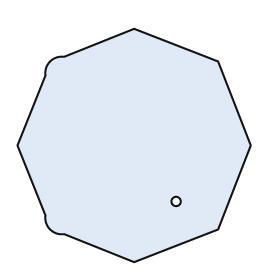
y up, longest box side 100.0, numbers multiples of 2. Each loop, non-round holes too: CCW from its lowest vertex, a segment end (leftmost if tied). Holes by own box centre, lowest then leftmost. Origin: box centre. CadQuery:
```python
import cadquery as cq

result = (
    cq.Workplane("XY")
    .moveTo(0.0, -50.0)
    .lineTo(36.0, -36.0)
    .lineTo(50.0, 0.0)
    .lineTo(36.0, 36.0)
    .lineTo(0.0, 50.0)
    .lineTo(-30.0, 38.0)
    .threePointArc((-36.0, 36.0), (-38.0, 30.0))
    .lineTo(-50.0, 0.0)
    .lineTo(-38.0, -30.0)
    .threePointArc((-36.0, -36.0), (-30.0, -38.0))
    .close()
    .moveTo(18.0, -24.0)
    .circle(2.0)
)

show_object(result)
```